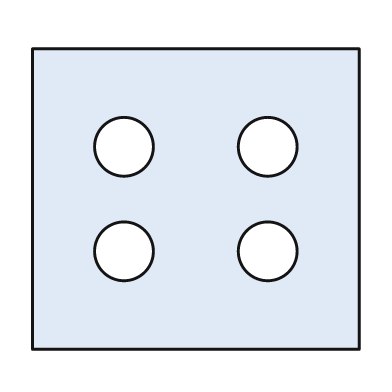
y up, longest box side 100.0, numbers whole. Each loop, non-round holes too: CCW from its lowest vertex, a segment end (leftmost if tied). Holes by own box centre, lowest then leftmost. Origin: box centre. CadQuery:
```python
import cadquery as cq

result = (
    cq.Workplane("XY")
    .moveTo(-50.0, -46.0)
    .lineTo(50.0, -46.0)
    .lineTo(50.0, 46.0)
    .lineTo(-50.0, 46.0)
    .close()
    .moveTo(-22.0, -16.0)
    .circle(9.0)
    .moveTo(22.0, -16.0)
    .circle(9.0)
    .moveTo(-22.0, 16.0)
    .circle(9.0)
    .moveTo(22.0, 16.0)
    .circle(9.0)
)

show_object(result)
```